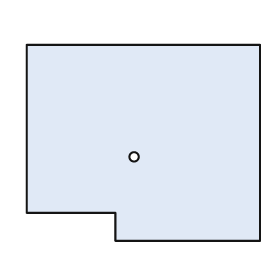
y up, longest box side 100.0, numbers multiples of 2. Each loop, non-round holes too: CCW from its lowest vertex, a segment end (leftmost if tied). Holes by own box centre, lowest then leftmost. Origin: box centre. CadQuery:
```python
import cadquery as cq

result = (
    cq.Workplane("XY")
    .moveTo(-12.0, -42.0)
    .lineTo(50.0, -42.0)
    .lineTo(50.0, 42.0)
    .lineTo(-50.0, 42.0)
    .lineTo(-50.0, -30.0)
    .lineTo(-12.0, -30.0)
    .close()
    .moveTo(-4.0, -6.0)
    .circle(2.0)
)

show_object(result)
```